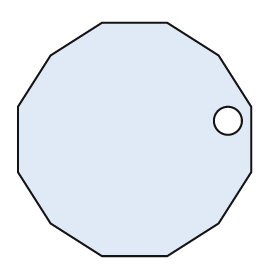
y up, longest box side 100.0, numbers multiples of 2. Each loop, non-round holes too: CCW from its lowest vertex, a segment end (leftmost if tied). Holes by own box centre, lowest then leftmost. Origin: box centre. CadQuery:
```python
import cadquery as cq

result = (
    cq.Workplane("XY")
    .moveTo(-14.0, -50.0)
    .lineTo(14.0, -50.0)
    .lineTo(36.0, -36.0)
    .lineTo(50.0, -14.0)
    .lineTo(50.0, 14.0)
    .lineTo(36.0, 36.0)
    .lineTo(14.0, 50.0)
    .lineTo(-14.0, 50.0)
    .lineTo(-36.0, 36.0)
    .lineTo(-50.0, 14.0)
    .lineTo(-50.0, -14.0)
    .lineTo(-36.0, -36.0)
    .close()
    .moveTo(40.0, 8.0)
    .circle(6.0)
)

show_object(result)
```